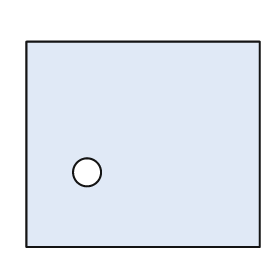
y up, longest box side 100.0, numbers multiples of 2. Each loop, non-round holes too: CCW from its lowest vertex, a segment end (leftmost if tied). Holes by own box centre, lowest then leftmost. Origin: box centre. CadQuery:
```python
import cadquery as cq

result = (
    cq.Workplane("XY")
    .moveTo(-50.0, -44.0)
    .lineTo(50.0, -44.0)
    .lineTo(50.0, 44.0)
    .lineTo(-50.0, 44.0)
    .close()
    .moveTo(-24.0, -12.0)
    .circle(6.0)
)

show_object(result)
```